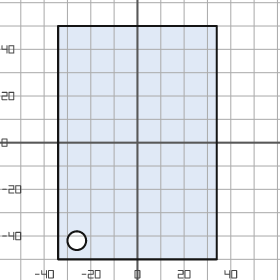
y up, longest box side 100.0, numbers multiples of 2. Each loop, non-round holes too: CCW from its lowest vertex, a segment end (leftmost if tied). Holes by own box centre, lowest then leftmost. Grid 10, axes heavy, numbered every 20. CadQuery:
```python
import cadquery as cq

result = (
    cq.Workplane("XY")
    .moveTo(-34.0, -50.0)
    .lineTo(34.0, -50.0)
    .lineTo(34.0, 50.0)
    .lineTo(-34.0, 50.0)
    .close()
    .moveTo(-26.0, -42.0)
    .circle(4.0)
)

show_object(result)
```